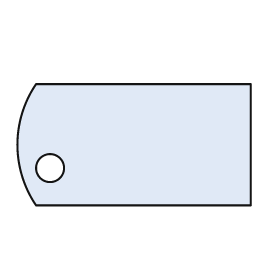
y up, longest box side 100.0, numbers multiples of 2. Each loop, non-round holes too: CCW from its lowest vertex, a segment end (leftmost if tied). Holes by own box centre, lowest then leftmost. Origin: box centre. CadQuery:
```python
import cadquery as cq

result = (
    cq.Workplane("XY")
    .moveTo(-42.0, -26.0)
    .lineTo(50.0, -26.0)
    .lineTo(50.0, 26.0)
    .lineTo(-42.0, 26.0)
    .threePointArc((-50.0, 0.0), (-42.0, -26.0))
    .close()
    .moveTo(-36.0, -10.0)
    .circle(6.0)
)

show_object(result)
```